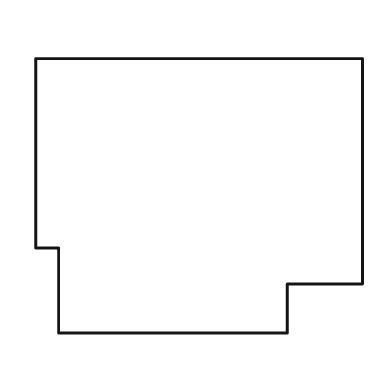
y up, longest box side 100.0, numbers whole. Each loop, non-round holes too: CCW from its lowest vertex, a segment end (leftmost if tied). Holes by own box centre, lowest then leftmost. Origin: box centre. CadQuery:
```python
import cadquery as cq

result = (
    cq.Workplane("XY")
    .moveTo(-43.0, -42.0)
    .lineTo(27.0, -42.0)
    .lineTo(27.0, -27.0)
    .lineTo(50.0, -27.0)
    .lineTo(50.0, 42.0)
    .lineTo(-50.0, 42.0)
    .lineTo(-50.0, -16.0)
    .lineTo(-43.0, -16.0)
    .close()
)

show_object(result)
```